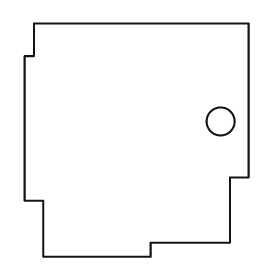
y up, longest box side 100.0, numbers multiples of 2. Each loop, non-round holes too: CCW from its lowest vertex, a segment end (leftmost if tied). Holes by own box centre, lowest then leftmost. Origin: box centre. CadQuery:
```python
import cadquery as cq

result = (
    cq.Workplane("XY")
    .moveTo(-40.0, -50.0)
    .lineTo(6.0, -50.0)
    .lineTo(6.0, -44.0)
    .lineTo(40.0, -44.0)
    .lineTo(40.0, -16.0)
    .lineTo(48.0, -16.0)
    .lineTo(48.0, 50.0)
    .lineTo(-44.0, 50.0)
    .lineTo(-44.0, 36.0)
    .lineTo(-48.0, 36.0)
    .lineTo(-48.0, -26.0)
    .lineTo(-40.0, -26.0)
    .close()
    .moveTo(36.0, 8.0)
    .circle(6.0)
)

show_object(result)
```